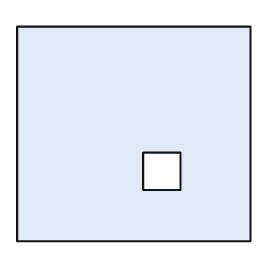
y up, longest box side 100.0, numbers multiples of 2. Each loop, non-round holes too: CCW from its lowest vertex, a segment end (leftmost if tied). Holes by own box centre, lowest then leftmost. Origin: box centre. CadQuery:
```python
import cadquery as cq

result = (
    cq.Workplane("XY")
    .moveTo(-50.0, -46.0)
    .lineTo(50.0, -46.0)
    .lineTo(50.0, 46.0)
    .lineTo(-50.0, 46.0)
    .close()
    .moveTo(4.0, -24.0)
    .lineTo(20.0, -24.0)
    .lineTo(20.0, -8.0)
    .lineTo(4.0, -8.0)
    .close()
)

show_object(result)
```